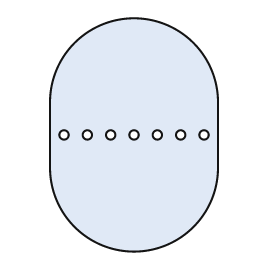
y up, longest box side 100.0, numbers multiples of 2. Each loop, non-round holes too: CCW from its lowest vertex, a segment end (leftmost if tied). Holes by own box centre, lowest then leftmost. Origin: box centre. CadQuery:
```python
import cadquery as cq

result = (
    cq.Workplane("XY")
    .moveTo(-36.0, -14.0)
    .threePointArc((0.0, -50.0), (36.0, -14.0))
    .lineTo(36.0, 14.0)
    .threePointArc((0.0, 50.0), (-36.0, 14.0))
    .close()
    .moveTo(-30.0, 0.0)
    .circle(2.0)
    .moveTo(-20.0, 0.0)
    .circle(2.0)
    .moveTo(-10.0, 0.0)
    .circle(2.0)
    .moveTo(0.0, 0.0)
    .circle(2.0)
    .moveTo(10.0, 0.0)
    .circle(2.0)
    .moveTo(20.0, 0.0)
    .circle(2.0)
    .moveTo(30.0, 0.0)
    .circle(2.0)
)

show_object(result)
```